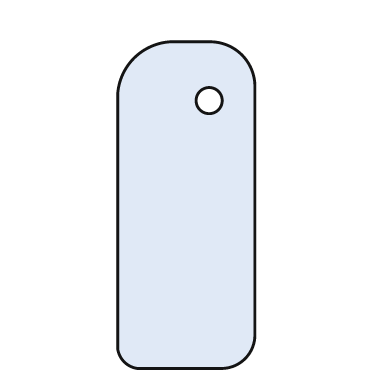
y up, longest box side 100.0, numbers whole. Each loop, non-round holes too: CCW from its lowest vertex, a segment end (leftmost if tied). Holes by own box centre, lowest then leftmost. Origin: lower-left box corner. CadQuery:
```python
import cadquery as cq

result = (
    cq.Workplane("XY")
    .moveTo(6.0, 0.0)
    .lineTo(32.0, 0.0)
    .threePointArc((39.0, 3.0), (42.0, 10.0))
    .lineTo(42.0, 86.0)
    .threePointArc((38.0, 96.0), (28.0, 100.0))
    .lineTo(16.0, 100.0)
    .threePointArc((5.0, 95.0), (0.0, 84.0))
    .lineTo(0.0, 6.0)
    .threePointArc((2.0, 2.0), (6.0, 0.0))
    .close()
    .moveTo(28.0, 82.0)
    .circle(4.0)
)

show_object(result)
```